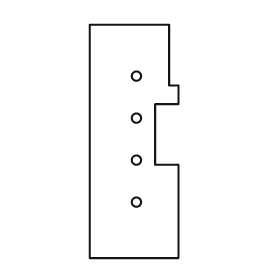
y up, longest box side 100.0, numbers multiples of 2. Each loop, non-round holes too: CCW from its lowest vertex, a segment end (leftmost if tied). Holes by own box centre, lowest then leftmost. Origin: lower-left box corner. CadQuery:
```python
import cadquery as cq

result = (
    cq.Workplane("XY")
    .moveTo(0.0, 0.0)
    .lineTo(38.0, 0.0)
    .lineTo(38.0, 40.0)
    .lineTo(28.0, 40.0)
    .lineTo(28.0, 66.0)
    .lineTo(38.0, 66.0)
    .lineTo(38.0, 74.0)
    .lineTo(34.0, 74.0)
    .lineTo(34.0, 100.0)
    .lineTo(0.0, 100.0)
    .close()
    .moveTo(20.0, 24.0)
    .circle(2.0)
    .moveTo(20.0, 42.0)
    .circle(2.0)
    .moveTo(20.0, 60.0)
    .circle(2.0)
    .moveTo(20.0, 78.0)
    .circle(2.0)
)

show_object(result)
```